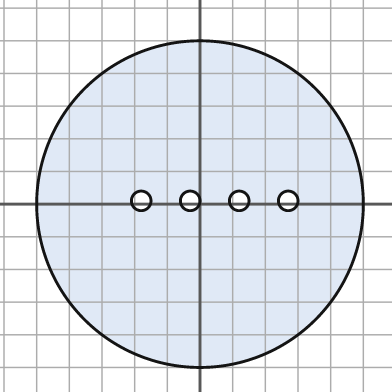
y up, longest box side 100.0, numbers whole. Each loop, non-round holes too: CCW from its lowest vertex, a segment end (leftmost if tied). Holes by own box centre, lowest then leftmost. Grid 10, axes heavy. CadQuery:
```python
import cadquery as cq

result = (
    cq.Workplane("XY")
    .moveTo(0.0, 0.0)
    .circle(50.0)
    .moveTo(-18.0, 1.0)
    .circle(3.0)
    .moveTo(-3.0, 1.0)
    .circle(3.0)
    .moveTo(12.0, 1.0)
    .circle(3.0)
    .moveTo(27.0, 1.0)
    .circle(3.0)
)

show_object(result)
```